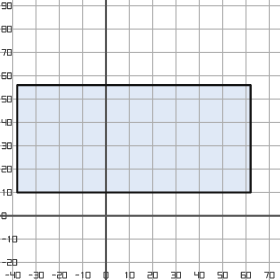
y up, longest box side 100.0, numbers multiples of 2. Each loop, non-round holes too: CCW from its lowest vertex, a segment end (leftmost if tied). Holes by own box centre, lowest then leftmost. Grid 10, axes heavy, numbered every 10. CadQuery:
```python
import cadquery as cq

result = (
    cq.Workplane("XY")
    .moveTo(-38.0, 10.0)
    .lineTo(62.0, 10.0)
    .lineTo(62.0, 56.0)
    .lineTo(-38.0, 56.0)
    .close()
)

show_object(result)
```